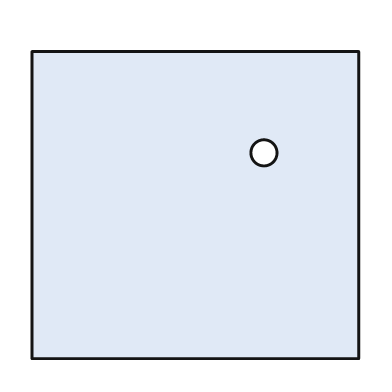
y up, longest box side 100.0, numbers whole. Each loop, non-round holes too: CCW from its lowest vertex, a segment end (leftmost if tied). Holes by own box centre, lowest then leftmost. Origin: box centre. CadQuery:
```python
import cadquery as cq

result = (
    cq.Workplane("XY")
    .moveTo(-50.0, -47.0)
    .lineTo(50.0, -47.0)
    .lineTo(50.0, 47.0)
    .lineTo(-50.0, 47.0)
    .close()
    .moveTo(21.0, 16.0)
    .circle(4.0)
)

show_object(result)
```